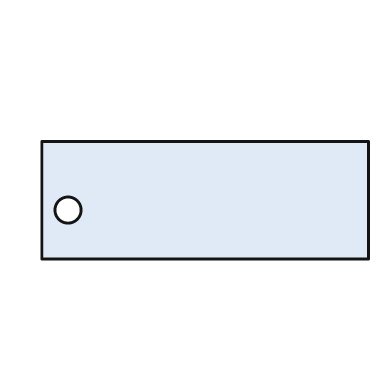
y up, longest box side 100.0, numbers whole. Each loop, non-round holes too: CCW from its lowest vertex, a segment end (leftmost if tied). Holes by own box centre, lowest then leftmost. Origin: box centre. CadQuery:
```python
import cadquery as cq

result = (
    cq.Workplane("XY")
    .moveTo(-50.0, -18.0)
    .lineTo(50.0, -18.0)
    .lineTo(50.0, 18.0)
    .lineTo(-50.0, 18.0)
    .close()
    .moveTo(-42.0, -3.0)
    .circle(4.0)
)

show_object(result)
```